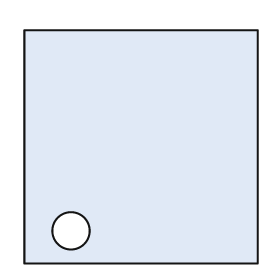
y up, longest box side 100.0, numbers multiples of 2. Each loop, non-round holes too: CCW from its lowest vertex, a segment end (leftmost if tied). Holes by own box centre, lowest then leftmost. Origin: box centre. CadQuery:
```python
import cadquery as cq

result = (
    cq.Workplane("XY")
    .moveTo(-50.0, -50.0)
    .lineTo(50.0, -50.0)
    .lineTo(50.0, 50.0)
    .lineTo(-50.0, 50.0)
    .close()
    .moveTo(-30.0, -36.0)
    .circle(8.0)
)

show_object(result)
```